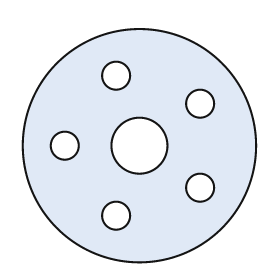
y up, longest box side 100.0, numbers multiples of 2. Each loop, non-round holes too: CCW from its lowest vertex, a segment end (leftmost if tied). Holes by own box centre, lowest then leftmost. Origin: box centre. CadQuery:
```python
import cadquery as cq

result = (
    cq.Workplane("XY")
    .moveTo(0.0, 0.0)
    .circle(50.0)
    .moveTo(-10.0, -30.0)
    .circle(6.0)
    .moveTo(26.0, -18.0)
    .circle(6.0)
    .moveTo(-32.0, 0.0)
    .circle(6.0)
    .moveTo(0.0, 0.0)
    .circle(12.0)
    .moveTo(26.0, 18.0)
    .circle(6.0)
    .moveTo(-10.0, 30.0)
    .circle(6.0)
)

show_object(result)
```